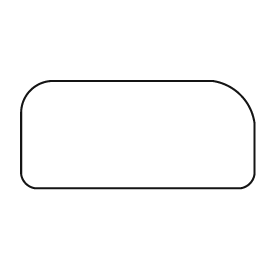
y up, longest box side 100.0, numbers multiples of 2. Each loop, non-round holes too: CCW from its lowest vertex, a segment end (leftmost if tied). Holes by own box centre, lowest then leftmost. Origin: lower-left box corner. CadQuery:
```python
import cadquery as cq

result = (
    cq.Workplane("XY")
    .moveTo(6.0, 0.0)
    .lineTo(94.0, 0.0)
    .threePointArc((98.0, 2.0), (100.0, 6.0))
    .lineTo(100.0, 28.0)
    .threePointArc((94.0, 40.0), (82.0, 46.0))
    .lineTo(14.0, 46.0)
    .threePointArc((4.0, 42.0), (0.0, 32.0))
    .lineTo(0.0, 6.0)
    .threePointArc((2.0, 2.0), (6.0, 0.0))
    .close()
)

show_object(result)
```